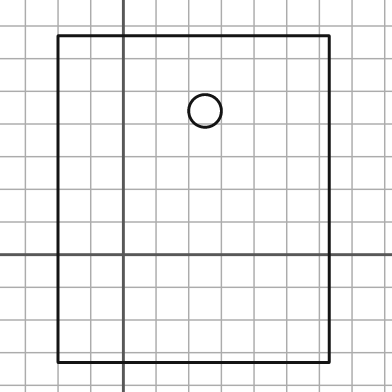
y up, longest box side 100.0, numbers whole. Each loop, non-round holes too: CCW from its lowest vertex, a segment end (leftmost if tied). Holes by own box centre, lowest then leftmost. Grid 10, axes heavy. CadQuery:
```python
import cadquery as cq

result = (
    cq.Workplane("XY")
    .moveTo(-20.0, -33.0)
    .lineTo(63.0, -33.0)
    .lineTo(63.0, 67.0)
    .lineTo(-20.0, 67.0)
    .close()
    .moveTo(25.0, 44.0)
    .circle(5.0)
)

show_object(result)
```